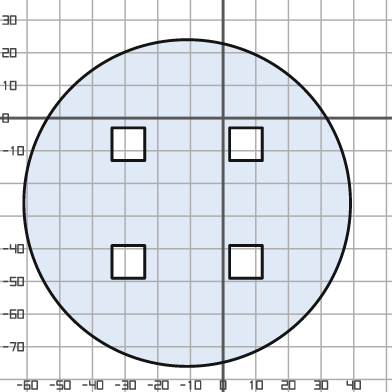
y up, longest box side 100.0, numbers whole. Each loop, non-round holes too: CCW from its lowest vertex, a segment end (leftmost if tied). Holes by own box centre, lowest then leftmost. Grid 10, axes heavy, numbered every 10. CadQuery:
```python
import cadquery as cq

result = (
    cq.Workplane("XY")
    .moveTo(-11.0, -26.0)
    .circle(50.0)
    .moveTo(-34.0, -49.0)
    .lineTo(-24.0, -49.0)
    .lineTo(-24.0, -39.0)
    .lineTo(-34.0, -39.0)
    .close()
    .moveTo(2.0, -49.0)
    .lineTo(12.0, -49.0)
    .lineTo(12.0, -39.0)
    .lineTo(2.0, -39.0)
    .close()
    .moveTo(-34.0, -13.0)
    .lineTo(-24.0, -13.0)
    .lineTo(-24.0, -3.0)
    .lineTo(-34.0, -3.0)
    .close()
    .moveTo(2.0, -13.0)
    .lineTo(12.0, -13.0)
    .lineTo(12.0, -3.0)
    .lineTo(2.0, -3.0)
    .close()
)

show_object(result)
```